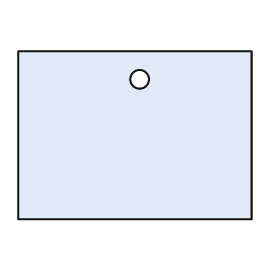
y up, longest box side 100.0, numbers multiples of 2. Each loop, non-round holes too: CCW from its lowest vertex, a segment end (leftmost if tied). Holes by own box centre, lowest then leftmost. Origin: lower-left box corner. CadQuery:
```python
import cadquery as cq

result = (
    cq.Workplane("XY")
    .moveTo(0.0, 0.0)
    .lineTo(100.0, 0.0)
    .lineTo(100.0, 72.0)
    .lineTo(0.0, 72.0)
    .close()
    .moveTo(52.0, 60.0)
    .circle(4.0)
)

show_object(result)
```